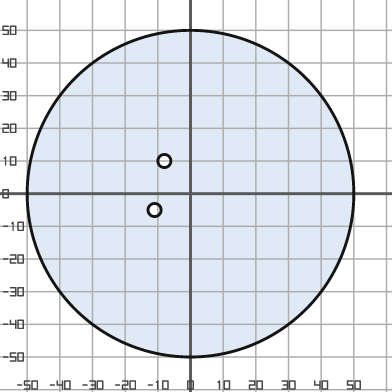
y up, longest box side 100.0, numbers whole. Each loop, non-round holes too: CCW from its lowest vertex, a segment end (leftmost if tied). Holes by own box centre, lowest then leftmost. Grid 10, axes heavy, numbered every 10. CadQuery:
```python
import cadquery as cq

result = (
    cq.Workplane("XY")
    .moveTo(0.0, 0.0)
    .circle(50.0)
    .moveTo(-11.0, -5.0)
    .circle(2.0)
    .moveTo(-8.0, 10.0)
    .circle(2.0)
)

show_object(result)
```